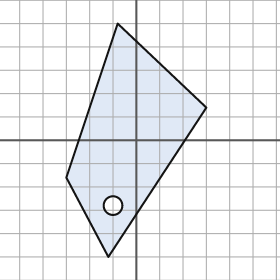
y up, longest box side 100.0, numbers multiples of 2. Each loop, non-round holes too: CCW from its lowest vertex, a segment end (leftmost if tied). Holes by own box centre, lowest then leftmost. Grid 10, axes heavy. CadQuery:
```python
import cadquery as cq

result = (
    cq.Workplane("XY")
    .moveTo(-12.0, -50.0)
    .lineTo(30.0, 14.0)
    .lineTo(-8.0, 50.0)
    .lineTo(-30.0, -16.0)
    .close()
    .moveTo(-10.0, -28.0)
    .circle(4.0)
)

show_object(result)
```